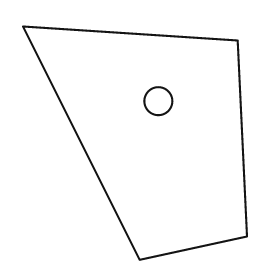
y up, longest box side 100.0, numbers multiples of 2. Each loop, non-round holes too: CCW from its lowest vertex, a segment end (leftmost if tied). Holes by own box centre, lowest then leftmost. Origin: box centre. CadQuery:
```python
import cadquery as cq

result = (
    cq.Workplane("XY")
    .moveTo(2.0, -50.0)
    .lineTo(48.0, -40.0)
    .lineTo(44.0, 44.0)
    .lineTo(-48.0, 50.0)
    .close()
    .moveTo(10.0, 18.0)
    .circle(6.0)
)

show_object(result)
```